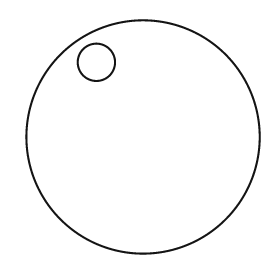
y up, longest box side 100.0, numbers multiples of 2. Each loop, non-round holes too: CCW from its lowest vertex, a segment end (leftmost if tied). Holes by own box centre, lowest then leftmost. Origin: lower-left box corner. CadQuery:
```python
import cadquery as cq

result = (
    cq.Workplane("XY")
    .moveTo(50.0, 50.0)
    .circle(50.0)
    .moveTo(30.0, 82.0)
    .circle(8.0)
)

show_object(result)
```